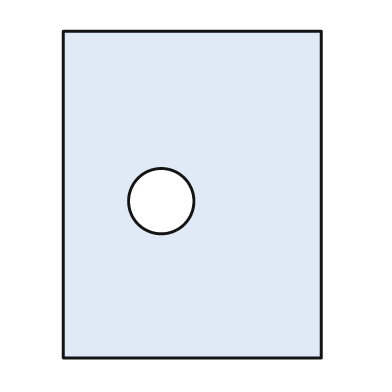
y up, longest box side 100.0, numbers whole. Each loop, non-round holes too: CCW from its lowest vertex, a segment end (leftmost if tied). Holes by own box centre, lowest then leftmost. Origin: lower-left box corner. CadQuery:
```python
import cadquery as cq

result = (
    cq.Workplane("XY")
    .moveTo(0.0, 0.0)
    .lineTo(79.0, 0.0)
    .lineTo(79.0, 100.0)
    .lineTo(0.0, 100.0)
    .close()
    .moveTo(30.0, 48.0)
    .circle(10.0)
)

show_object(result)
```